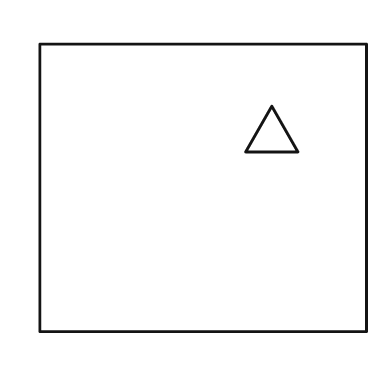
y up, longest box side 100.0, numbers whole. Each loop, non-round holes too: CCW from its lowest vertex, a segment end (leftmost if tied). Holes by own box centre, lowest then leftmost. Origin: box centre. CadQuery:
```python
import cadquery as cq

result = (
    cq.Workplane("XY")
    .moveTo(-50.0, -44.0)
    .lineTo(50.0, -44.0)
    .lineTo(50.0, 44.0)
    .lineTo(-50.0, 44.0)
    .close()
    .moveTo(13.0, 11.0)
    .lineTo(29.0, 11.0)
    .lineTo(21.0, 25.0)
    .close()
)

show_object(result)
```